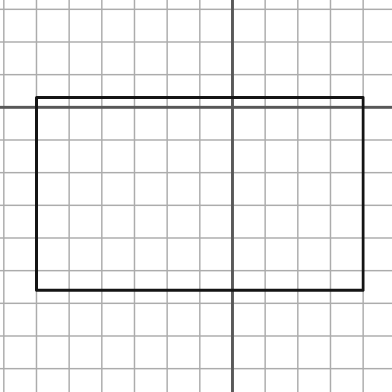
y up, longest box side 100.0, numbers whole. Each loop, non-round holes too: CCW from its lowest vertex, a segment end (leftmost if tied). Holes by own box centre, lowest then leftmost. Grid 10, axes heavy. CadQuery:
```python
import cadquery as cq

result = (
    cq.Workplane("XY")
    .moveTo(-60.0, -56.0)
    .lineTo(40.0, -56.0)
    .lineTo(40.0, 3.0)
    .lineTo(-60.0, 3.0)
    .close()
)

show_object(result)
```